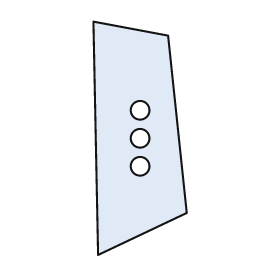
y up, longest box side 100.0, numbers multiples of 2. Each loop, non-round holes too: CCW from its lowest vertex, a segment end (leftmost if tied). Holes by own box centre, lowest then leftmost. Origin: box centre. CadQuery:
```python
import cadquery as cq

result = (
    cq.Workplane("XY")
    .moveTo(-18.0, -50.0)
    .lineTo(20.0, -32.0)
    .lineTo(12.0, 44.0)
    .lineTo(-20.0, 50.0)
    .close()
    .moveTo(0.0, -12.0)
    .circle(4.0)
    .moveTo(0.0, 0.0)
    .circle(4.0)
    .moveTo(0.0, 12.0)
    .circle(4.0)
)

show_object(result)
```